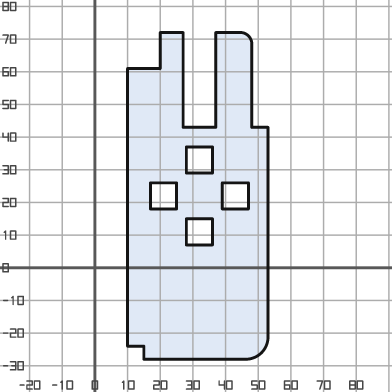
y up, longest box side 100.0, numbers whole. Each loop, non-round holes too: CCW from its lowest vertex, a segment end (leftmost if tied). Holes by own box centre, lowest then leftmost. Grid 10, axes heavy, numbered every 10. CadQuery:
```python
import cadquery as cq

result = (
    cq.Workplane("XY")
    .moveTo(15.0, -28.0)
    .lineTo(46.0, -28.0)
    .threePointArc((51.0, -26.0), (53.0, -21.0))
    .lineTo(53.0, 43.0)
    .lineTo(48.0, 43.0)
    .lineTo(48.0, 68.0)
    .threePointArc((47.0, 71.0), (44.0, 72.0))
    .lineTo(37.0, 72.0)
    .lineTo(37.0, 43.0)
    .lineTo(27.0, 43.0)
    .lineTo(27.0, 72.0)
    .lineTo(20.0, 72.0)
    .lineTo(20.0, 61.0)
    .lineTo(10.0, 61.0)
    .lineTo(10.0, -24.0)
    .lineTo(15.0, -24.0)
    .close()
    .moveTo(28.0, 7.0)
    .lineTo(36.0, 7.0)
    .lineTo(36.0, 15.0)
    .lineTo(28.0, 15.0)
    .close()
    .moveTo(17.0, 18.0)
    .lineTo(25.0, 18.0)
    .lineTo(25.0, 26.0)
    .lineTo(17.0, 26.0)
    .close()
    .moveTo(39.0, 18.0)
    .lineTo(47.0, 18.0)
    .lineTo(47.0, 26.0)
    .lineTo(39.0, 26.0)
    .close()
    .moveTo(28.0, 29.0)
    .lineTo(36.0, 29.0)
    .lineTo(36.0, 37.0)
    .lineTo(28.0, 37.0)
    .close()
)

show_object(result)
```